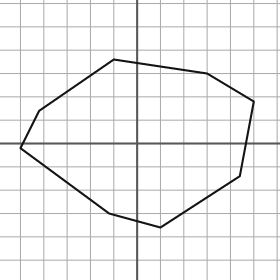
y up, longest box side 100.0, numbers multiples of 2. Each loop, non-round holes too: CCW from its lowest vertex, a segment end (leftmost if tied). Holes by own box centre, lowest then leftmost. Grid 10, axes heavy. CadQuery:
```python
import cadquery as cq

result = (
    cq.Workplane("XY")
    .moveTo(10.0, -36.0)
    .lineTo(44.0, -14.0)
    .lineTo(50.0, 18.0)
    .lineTo(30.0, 30.0)
    .lineTo(-10.0, 36.0)
    .lineTo(-42.0, 14.0)
    .lineTo(-50.0, -2.0)
    .lineTo(-12.0, -30.0)
    .close()
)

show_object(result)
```